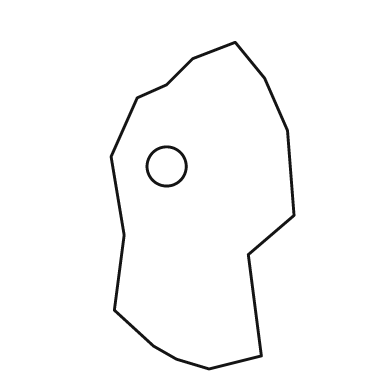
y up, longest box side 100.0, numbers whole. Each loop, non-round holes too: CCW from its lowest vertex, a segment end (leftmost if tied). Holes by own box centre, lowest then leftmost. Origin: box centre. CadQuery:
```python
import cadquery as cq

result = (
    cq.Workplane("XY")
    .moveTo(2.0, -50.0)
    .lineTo(18.0, -46.0)
    .lineTo(14.0, -15.0)
    .lineTo(28.0, -3.0)
    .lineTo(26.0, 23.0)
    .lineTo(19.0, 39.0)
    .lineTo(10.0, 50.0)
    .lineTo(-3.0, 45.0)
    .lineTo(-11.0, 37.0)
    .lineTo(-20.0, 33.0)
    .lineTo(-28.0, 15.0)
    .lineTo(-24.0, -9.0)
    .lineTo(-27.0, -32.0)
    .lineTo(-15.0, -43.0)
    .lineTo(-8.0, -47.0)
    .close()
    .moveTo(-11.0, 12.0)
    .circle(6.0)
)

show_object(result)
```